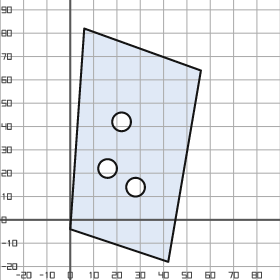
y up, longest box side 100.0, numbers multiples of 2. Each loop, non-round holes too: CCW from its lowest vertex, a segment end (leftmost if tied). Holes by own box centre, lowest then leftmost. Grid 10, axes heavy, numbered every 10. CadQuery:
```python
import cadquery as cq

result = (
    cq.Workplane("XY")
    .moveTo(42.0, -18.0)
    .lineTo(56.0, 64.0)
    .lineTo(6.0, 82.0)
    .lineTo(0.0, -4.0)
    .close()
    .moveTo(28.0, 14.0)
    .circle(4.0)
    .moveTo(16.0, 22.0)
    .circle(4.0)
    .moveTo(22.0, 42.0)
    .circle(4.0)
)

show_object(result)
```